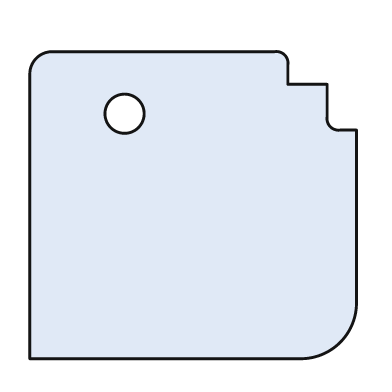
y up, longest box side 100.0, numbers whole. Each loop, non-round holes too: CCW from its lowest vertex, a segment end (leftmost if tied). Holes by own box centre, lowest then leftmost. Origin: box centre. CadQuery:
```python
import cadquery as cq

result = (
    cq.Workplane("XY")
    .moveTo(-50.0, -47.0)
    .lineTo(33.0, -47.0)
    .threePointArc((45.0, -42.0), (50.0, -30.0))
    .lineTo(50.0, 23.0)
    .lineTo(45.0, 23.0)
    .threePointArc((42.0, 24.0), (41.0, 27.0))
    .lineTo(41.0, 37.0)
    .lineTo(29.0, 37.0)
    .lineTo(29.0, 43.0)
    .threePointArc((28.0, 46.0), (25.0, 47.0))
    .lineTo(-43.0, 47.0)
    .threePointArc((-48.0, 45.0), (-50.0, 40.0))
    .close()
    .moveTo(-21.0, 28.0)
    .circle(6.0)
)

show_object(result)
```